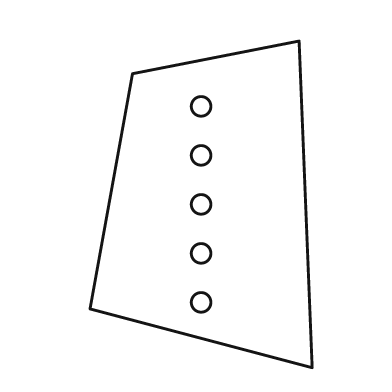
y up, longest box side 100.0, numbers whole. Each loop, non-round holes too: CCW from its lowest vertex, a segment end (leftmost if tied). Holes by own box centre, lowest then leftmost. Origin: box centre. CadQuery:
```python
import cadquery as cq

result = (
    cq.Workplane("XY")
    .moveTo(34.0, -50.0)
    .lineTo(30.0, 50.0)
    .lineTo(-21.0, 40.0)
    .lineTo(-34.0, -32.0)
    .close()
    .moveTo(0.0, -30.0)
    .circle(3.0)
    .moveTo(0.0, -15.0)
    .circle(3.0)
    .moveTo(0.0, 0.0)
    .circle(3.0)
    .moveTo(0.0, 15.0)
    .circle(3.0)
    .moveTo(0.0, 30.0)
    .circle(3.0)
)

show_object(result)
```